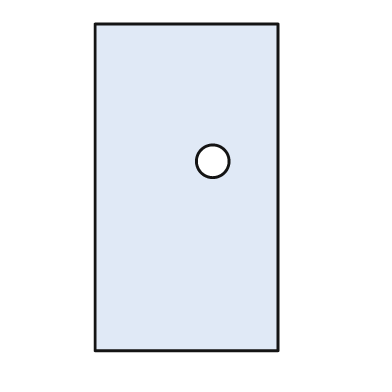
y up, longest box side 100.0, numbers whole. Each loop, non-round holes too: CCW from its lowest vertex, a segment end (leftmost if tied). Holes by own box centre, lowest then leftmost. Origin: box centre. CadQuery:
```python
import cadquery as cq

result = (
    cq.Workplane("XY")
    .moveTo(-28.0, -50.0)
    .lineTo(28.0, -50.0)
    .lineTo(28.0, 50.0)
    .lineTo(-28.0, 50.0)
    .close()
    .moveTo(8.0, 8.0)
    .circle(5.0)
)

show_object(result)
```